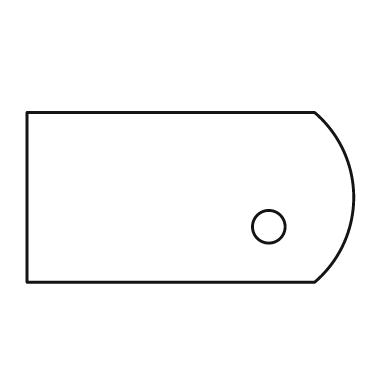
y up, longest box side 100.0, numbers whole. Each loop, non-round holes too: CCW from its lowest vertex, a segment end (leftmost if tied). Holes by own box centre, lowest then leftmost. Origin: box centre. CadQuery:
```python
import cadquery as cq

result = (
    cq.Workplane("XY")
    .moveTo(-50.0, -26.0)
    .lineTo(38.0, -26.0)
    .threePointArc((50.0, 0.0), (38.0, 26.0))
    .lineTo(-50.0, 26.0)
    .close()
    .moveTo(24.0, -9.0)
    .circle(5.0)
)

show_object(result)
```